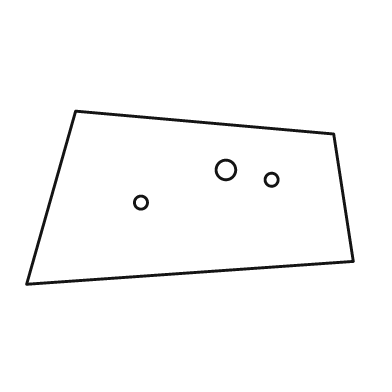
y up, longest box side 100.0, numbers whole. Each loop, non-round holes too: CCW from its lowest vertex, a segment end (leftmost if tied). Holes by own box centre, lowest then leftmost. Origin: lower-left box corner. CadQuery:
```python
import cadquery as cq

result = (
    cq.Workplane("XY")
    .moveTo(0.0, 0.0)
    .lineTo(100.0, 7.0)
    .lineTo(94.0, 46.0)
    .lineTo(15.0, 53.0)
    .close()
    .moveTo(35.0, 25.0)
    .circle(2.0)
    .moveTo(75.0, 32.0)
    .circle(2.0)
    .moveTo(61.0, 35.0)
    .circle(3.0)
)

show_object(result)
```